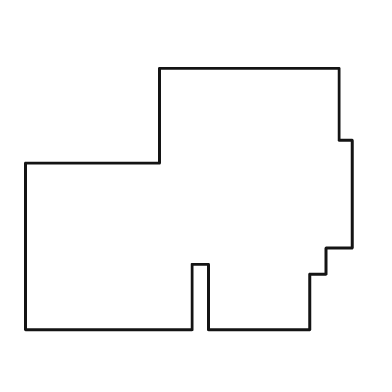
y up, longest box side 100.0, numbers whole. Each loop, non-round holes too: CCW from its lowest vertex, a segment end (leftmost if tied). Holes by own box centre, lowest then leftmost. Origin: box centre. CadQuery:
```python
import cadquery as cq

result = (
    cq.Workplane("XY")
    .moveTo(-50.0, -40.0)
    .lineTo(1.0, -40.0)
    .lineTo(1.0, -20.0)
    .lineTo(6.0, -20.0)
    .lineTo(6.0, -40.0)
    .lineTo(37.0, -40.0)
    .lineTo(37.0, -23.0)
    .lineTo(42.0, -23.0)
    .lineTo(42.0, -15.0)
    .lineTo(50.0, -15.0)
    .lineTo(50.0, 18.0)
    .lineTo(46.0, 18.0)
    .lineTo(46.0, 40.0)
    .lineTo(-9.0, 40.0)
    .lineTo(-9.0, 11.0)
    .lineTo(-50.0, 11.0)
    .close()
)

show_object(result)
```